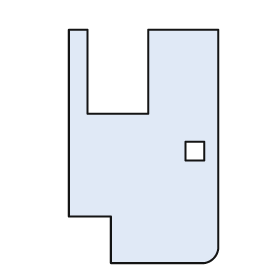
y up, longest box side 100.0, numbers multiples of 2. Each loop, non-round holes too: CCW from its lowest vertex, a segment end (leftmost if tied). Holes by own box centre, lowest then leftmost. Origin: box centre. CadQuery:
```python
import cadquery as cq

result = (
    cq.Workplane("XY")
    .moveTo(-14.0, -50.0)
    .lineTo(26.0, -50.0)
    .threePointArc((30.0, -48.0), (32.0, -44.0))
    .lineTo(32.0, 50.0)
    .lineTo(2.0, 50.0)
    .lineTo(2.0, 14.0)
    .lineTo(-24.0, 14.0)
    .lineTo(-24.0, 50.0)
    .lineTo(-32.0, 50.0)
    .lineTo(-32.0, -30.0)
    .lineTo(-14.0, -30.0)
    .close()
    .moveTo(18.0, -6.0)
    .lineTo(26.0, -6.0)
    .lineTo(26.0, 2.0)
    .lineTo(18.0, 2.0)
    .close()
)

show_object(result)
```